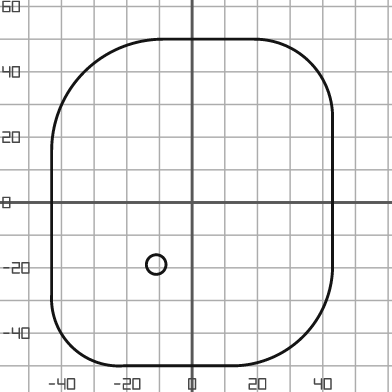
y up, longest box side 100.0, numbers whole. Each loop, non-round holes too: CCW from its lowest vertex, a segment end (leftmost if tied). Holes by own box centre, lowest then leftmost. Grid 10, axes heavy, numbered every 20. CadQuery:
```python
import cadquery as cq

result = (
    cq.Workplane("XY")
    .moveTo(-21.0, -50.0)
    .lineTo(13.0, -50.0)
    .threePointArc((34.0, -41.0), (43.0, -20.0))
    .lineTo(43.0, 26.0)
    .threePointArc((36.0, 43.0), (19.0, 50.0))
    .lineTo(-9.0, 50.0)
    .threePointArc((-33.0, 40.0), (-43.0, 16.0))
    .lineTo(-43.0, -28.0)
    .threePointArc((-37.0, -44.0), (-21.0, -50.0))
    .close()
    .moveTo(-11.0, -19.0)
    .circle(3.0)
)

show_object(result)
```